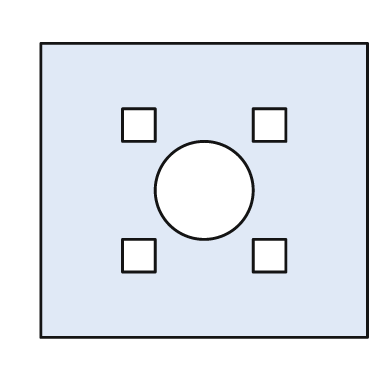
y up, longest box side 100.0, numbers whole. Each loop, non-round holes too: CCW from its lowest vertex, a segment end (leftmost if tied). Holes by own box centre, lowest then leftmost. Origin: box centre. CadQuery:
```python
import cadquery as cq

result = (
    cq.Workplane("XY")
    .moveTo(-50.0, -45.0)
    .lineTo(50.0, -45.0)
    .lineTo(50.0, 45.0)
    .lineTo(-50.0, 45.0)
    .close()
    .moveTo(-25.0, -25.0)
    .lineTo(-15.0, -25.0)
    .lineTo(-15.0, -15.0)
    .lineTo(-25.0, -15.0)
    .close()
    .moveTo(15.0, -25.0)
    .lineTo(25.0, -25.0)
    .lineTo(25.0, -15.0)
    .lineTo(15.0, -15.0)
    .close()
    .moveTo(0.0, 0.0)
    .circle(15.0)
    .moveTo(-25.0, 15.0)
    .lineTo(-15.0, 15.0)
    .lineTo(-15.0, 25.0)
    .lineTo(-25.0, 25.0)
    .close()
    .moveTo(15.0, 15.0)
    .lineTo(25.0, 15.0)
    .lineTo(25.0, 25.0)
    .lineTo(15.0, 25.0)
    .close()
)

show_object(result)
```